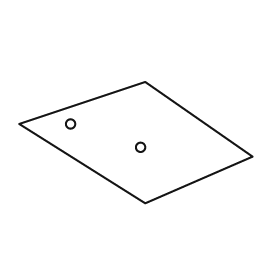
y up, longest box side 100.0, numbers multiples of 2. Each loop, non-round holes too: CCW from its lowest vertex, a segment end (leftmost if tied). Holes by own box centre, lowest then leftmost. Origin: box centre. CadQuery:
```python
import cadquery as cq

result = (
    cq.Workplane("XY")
    .moveTo(4.0, -26.0)
    .lineTo(50.0, -6.0)
    .lineTo(4.0, 26.0)
    .lineTo(-50.0, 8.0)
    .close()
    .moveTo(2.0, -2.0)
    .circle(2.0)
    .moveTo(-28.0, 8.0)
    .circle(2.0)
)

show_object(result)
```